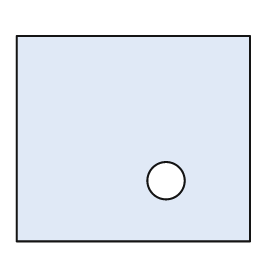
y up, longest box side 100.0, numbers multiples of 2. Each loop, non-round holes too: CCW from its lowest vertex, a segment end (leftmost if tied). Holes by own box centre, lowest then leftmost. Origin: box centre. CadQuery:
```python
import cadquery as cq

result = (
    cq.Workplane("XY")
    .moveTo(-50.0, -44.0)
    .lineTo(50.0, -44.0)
    .lineTo(50.0, 44.0)
    .lineTo(-50.0, 44.0)
    .close()
    .moveTo(14.0, -18.0)
    .circle(8.0)
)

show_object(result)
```